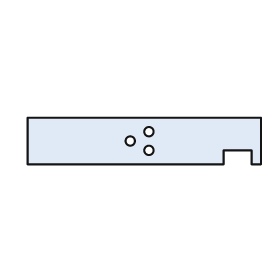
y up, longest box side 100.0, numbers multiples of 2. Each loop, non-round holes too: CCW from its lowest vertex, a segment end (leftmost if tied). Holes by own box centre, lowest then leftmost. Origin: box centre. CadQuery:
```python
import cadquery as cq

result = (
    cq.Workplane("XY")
    .moveTo(-50.0, -10.0)
    .lineTo(34.0, -10.0)
    .lineTo(34.0, -4.0)
    .lineTo(46.0, -4.0)
    .lineTo(46.0, -10.0)
    .lineTo(50.0, -10.0)
    .lineTo(50.0, 10.0)
    .lineTo(-50.0, 10.0)
    .close()
    .moveTo(2.0, -4.0)
    .circle(2.0)
    .moveTo(-6.0, 0.0)
    .circle(2.0)
    .moveTo(2.0, 4.0)
    .circle(2.0)
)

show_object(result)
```